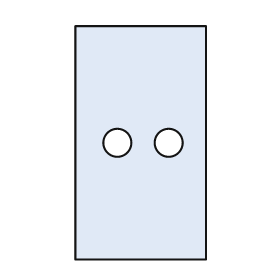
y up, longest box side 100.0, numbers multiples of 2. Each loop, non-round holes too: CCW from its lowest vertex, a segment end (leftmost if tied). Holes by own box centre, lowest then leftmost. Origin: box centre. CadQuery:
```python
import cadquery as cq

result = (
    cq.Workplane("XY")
    .moveTo(-28.0, -50.0)
    .lineTo(28.0, -50.0)
    .lineTo(28.0, 50.0)
    .lineTo(-28.0, 50.0)
    .close()
    .moveTo(-10.0, 0.0)
    .circle(6.0)
    .moveTo(12.0, 0.0)
    .circle(6.0)
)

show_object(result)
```